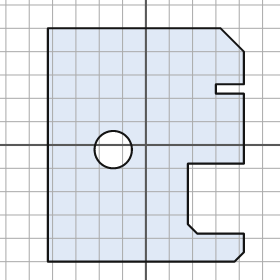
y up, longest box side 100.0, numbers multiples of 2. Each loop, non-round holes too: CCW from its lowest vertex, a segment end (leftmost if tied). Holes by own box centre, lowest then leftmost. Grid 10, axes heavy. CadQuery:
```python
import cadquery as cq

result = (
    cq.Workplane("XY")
    .moveTo(-42.0, -50.0)
    .lineTo(38.0, -50.0)
    .lineTo(42.0, -46.0)
    .lineTo(42.0, -38.0)
    .lineTo(22.0, -38.0)
    .lineTo(18.0, -34.0)
    .lineTo(18.0, -8.0)
    .lineTo(42.0, -8.0)
    .lineTo(42.0, 22.0)
    .lineTo(30.0, 22.0)
    .lineTo(30.0, 26.0)
    .lineTo(42.0, 26.0)
    .lineTo(42.0, 40.0)
    .lineTo(32.0, 50.0)
    .lineTo(-42.0, 50.0)
    .close()
    .moveTo(-14.0, -2.0)
    .circle(8.0)
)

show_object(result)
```